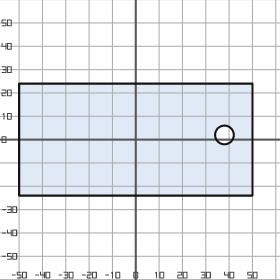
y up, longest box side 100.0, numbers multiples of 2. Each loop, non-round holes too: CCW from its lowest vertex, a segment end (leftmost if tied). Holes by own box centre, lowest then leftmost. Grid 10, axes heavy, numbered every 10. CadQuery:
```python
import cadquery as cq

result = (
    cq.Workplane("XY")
    .moveTo(-50.0, -24.0)
    .lineTo(50.0, -24.0)
    .lineTo(50.0, 24.0)
    .lineTo(-50.0, 24.0)
    .close()
    .moveTo(38.0, 2.0)
    .circle(4.0)
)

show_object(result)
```